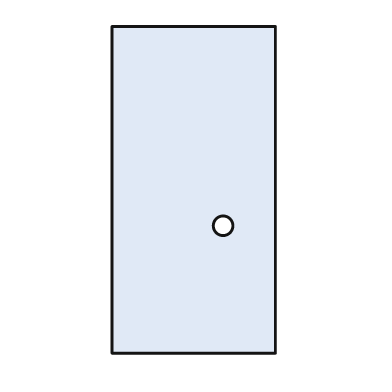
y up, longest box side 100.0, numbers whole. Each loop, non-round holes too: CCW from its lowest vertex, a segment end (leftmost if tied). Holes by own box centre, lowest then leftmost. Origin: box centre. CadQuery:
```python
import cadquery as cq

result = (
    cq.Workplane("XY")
    .moveTo(-25.0, -50.0)
    .lineTo(25.0, -50.0)
    .lineTo(25.0, 50.0)
    .lineTo(-25.0, 50.0)
    .close()
    .moveTo(9.0, -11.0)
    .circle(3.0)
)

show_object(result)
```